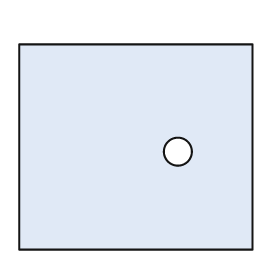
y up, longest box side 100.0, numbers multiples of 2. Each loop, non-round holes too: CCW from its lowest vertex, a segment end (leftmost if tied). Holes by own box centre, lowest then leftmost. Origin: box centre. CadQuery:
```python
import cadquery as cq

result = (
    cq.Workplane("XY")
    .moveTo(-50.0, -44.0)
    .lineTo(50.0, -44.0)
    .lineTo(50.0, 44.0)
    .lineTo(-50.0, 44.0)
    .close()
    .moveTo(18.0, -2.0)
    .circle(6.0)
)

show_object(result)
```